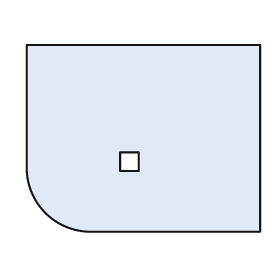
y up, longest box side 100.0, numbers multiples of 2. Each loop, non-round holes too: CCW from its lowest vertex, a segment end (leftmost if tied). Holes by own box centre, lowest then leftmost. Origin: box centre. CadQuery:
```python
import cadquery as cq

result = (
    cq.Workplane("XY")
    .moveTo(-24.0, -40.0)
    .lineTo(50.0, -40.0)
    .lineTo(50.0, 40.0)
    .lineTo(-50.0, 40.0)
    .lineTo(-50.0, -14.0)
    .threePointArc((-42.0, -32.0), (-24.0, -40.0))
    .close()
    .moveTo(-10.0, -14.0)
    .lineTo(-2.0, -14.0)
    .lineTo(-2.0, -6.0)
    .lineTo(-10.0, -6.0)
    .close()
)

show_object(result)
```